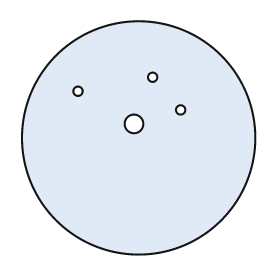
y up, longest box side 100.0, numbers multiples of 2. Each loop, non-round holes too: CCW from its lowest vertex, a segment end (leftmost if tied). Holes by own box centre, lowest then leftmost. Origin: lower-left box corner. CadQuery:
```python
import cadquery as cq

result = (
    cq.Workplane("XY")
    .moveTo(50.0, 50.0)
    .circle(50.0)
    .moveTo(48.0, 56.0)
    .circle(4.0)
    .moveTo(68.0, 62.0)
    .circle(2.0)
    .moveTo(24.0, 70.0)
    .circle(2.0)
    .moveTo(56.0, 76.0)
    .circle(2.0)
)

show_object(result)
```